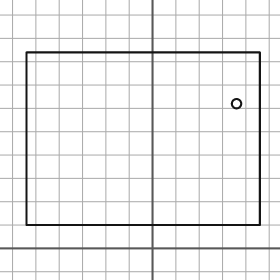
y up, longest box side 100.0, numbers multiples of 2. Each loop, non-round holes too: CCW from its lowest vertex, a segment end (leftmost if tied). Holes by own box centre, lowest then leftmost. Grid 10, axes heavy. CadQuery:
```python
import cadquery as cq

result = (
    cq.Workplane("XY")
    .moveTo(-54.0, 10.0)
    .lineTo(46.0, 10.0)
    .lineTo(46.0, 84.0)
    .lineTo(-54.0, 84.0)
    .close()
    .moveTo(36.0, 62.0)
    .circle(2.0)
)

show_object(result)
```